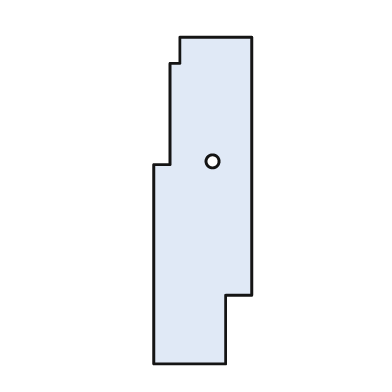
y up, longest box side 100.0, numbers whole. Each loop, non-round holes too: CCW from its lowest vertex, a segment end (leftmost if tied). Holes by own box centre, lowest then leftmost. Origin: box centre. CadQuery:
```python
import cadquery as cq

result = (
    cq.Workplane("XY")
    .moveTo(-15.0, -50.0)
    .lineTo(7.0, -50.0)
    .lineTo(7.0, -29.0)
    .lineTo(15.0, -29.0)
    .lineTo(15.0, 50.0)
    .lineTo(-7.0, 50.0)
    .lineTo(-7.0, 42.0)
    .lineTo(-10.0, 42.0)
    .lineTo(-10.0, 11.0)
    .lineTo(-15.0, 11.0)
    .close()
    .moveTo(3.0, 12.0)
    .circle(2.0)
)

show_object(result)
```